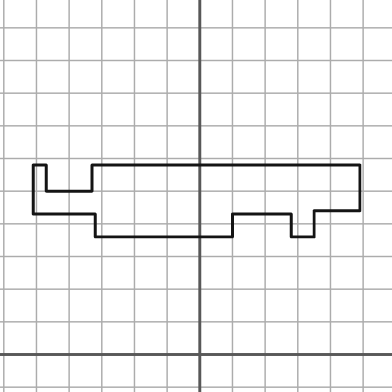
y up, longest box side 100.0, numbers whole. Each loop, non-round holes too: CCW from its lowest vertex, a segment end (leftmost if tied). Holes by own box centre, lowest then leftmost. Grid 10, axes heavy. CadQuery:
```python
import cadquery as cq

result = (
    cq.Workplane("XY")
    .moveTo(-32.0, 36.0)
    .lineTo(10.0, 36.0)
    .lineTo(10.0, 43.0)
    .lineTo(28.0, 43.0)
    .lineTo(28.0, 36.0)
    .lineTo(35.0, 36.0)
    .lineTo(35.0, 44.0)
    .lineTo(49.0, 44.0)
    .lineTo(49.0, 58.0)
    .lineTo(-33.0, 58.0)
    .lineTo(-33.0, 50.0)
    .lineTo(-47.0, 50.0)
    .lineTo(-47.0, 58.0)
    .lineTo(-51.0, 58.0)
    .lineTo(-51.0, 43.0)
    .lineTo(-32.0, 43.0)
    .close()
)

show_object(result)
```